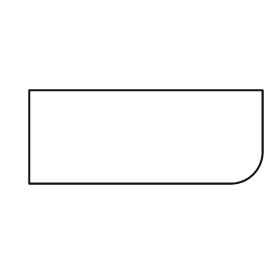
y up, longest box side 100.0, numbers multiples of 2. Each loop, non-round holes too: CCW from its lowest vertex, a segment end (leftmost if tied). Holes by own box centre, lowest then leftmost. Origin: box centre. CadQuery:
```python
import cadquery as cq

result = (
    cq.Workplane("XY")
    .moveTo(-50.0, -20.0)
    .lineTo(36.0, -20.0)
    .threePointArc((46.0, -16.0), (50.0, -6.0))
    .lineTo(50.0, 20.0)
    .lineTo(-50.0, 20.0)
    .close()
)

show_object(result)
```